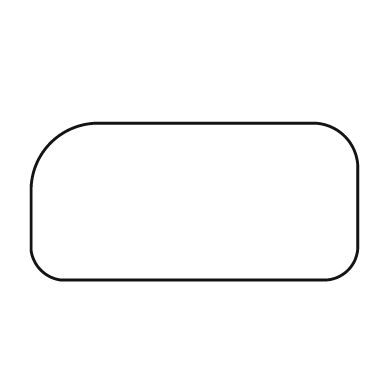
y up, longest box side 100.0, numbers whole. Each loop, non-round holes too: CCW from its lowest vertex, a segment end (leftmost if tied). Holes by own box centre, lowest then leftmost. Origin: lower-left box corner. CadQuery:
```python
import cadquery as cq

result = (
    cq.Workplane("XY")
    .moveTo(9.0, 0.0)
    .lineTo(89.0, 0.0)
    .threePointArc((97.0, 3.0), (100.0, 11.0))
    .lineTo(100.0, 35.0)
    .threePointArc((96.0, 44.0), (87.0, 48.0))
    .lineTo(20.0, 48.0)
    .threePointArc((6.0, 42.0), (0.0, 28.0))
    .lineTo(0.0, 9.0)
    .threePointArc((3.0, 3.0), (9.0, 0.0))
    .close()
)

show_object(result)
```